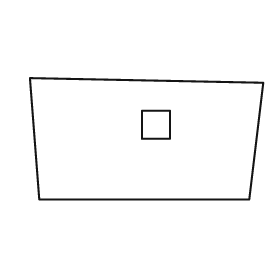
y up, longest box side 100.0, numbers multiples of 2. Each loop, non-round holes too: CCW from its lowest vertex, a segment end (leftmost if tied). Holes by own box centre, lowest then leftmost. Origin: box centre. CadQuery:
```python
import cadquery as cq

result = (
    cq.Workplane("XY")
    .moveTo(-46.0, -26.0)
    .lineTo(44.0, -26.0)
    .lineTo(50.0, 24.0)
    .lineTo(-50.0, 26.0)
    .close()
    .moveTo(-2.0, 0.0)
    .lineTo(10.0, 0.0)
    .lineTo(10.0, 12.0)
    .lineTo(-2.0, 12.0)
    .close()
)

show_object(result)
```